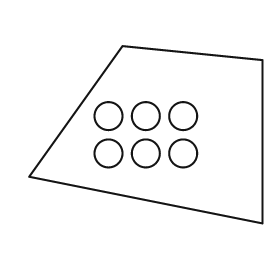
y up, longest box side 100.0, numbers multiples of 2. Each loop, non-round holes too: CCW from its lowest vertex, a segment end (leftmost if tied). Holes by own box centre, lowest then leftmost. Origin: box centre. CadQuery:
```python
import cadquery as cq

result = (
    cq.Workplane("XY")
    .moveTo(50.0, -38.0)
    .lineTo(50.0, 32.0)
    .lineTo(-10.0, 38.0)
    .lineTo(-50.0, -18.0)
    .close()
    .moveTo(-16.0, -8.0)
    .circle(6.0)
    .moveTo(0.0, -8.0)
    .circle(6.0)
    .moveTo(16.0, -8.0)
    .circle(6.0)
    .moveTo(-16.0, 8.0)
    .circle(6.0)
    .moveTo(0.0, 8.0)
    .circle(6.0)
    .moveTo(16.0, 8.0)
    .circle(6.0)
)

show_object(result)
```